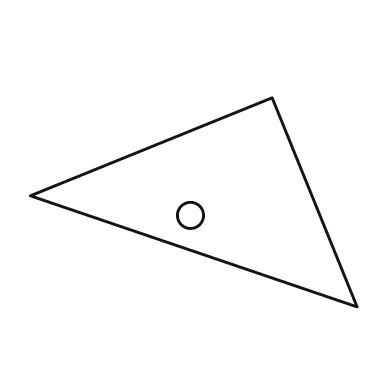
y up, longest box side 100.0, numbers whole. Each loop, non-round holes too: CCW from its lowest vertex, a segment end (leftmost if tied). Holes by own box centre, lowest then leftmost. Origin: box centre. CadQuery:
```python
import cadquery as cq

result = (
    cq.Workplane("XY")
    .moveTo(50.0, -32.0)
    .lineTo(24.0, 32.0)
    .lineTo(-50.0, 2.0)
    .close()
    .moveTo(-1.0, -4.0)
    .circle(4.0)
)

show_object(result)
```